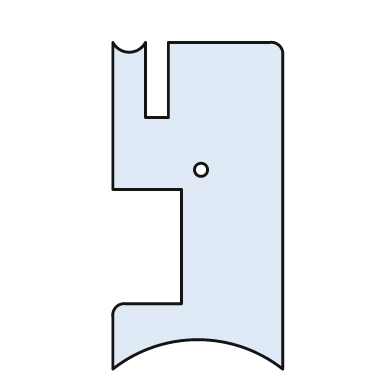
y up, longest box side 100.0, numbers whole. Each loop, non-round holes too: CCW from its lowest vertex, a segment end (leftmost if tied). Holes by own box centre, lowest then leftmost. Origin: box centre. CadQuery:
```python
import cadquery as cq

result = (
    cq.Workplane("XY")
    .moveTo(-26.0, -50.0)
    .threePointArc((0.0, -41.0), (26.0, -50.0))
    .lineTo(26.0, 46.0)
    .threePointArc((25.0, 49.0), (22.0, 50.0))
    .lineTo(-9.0, 50.0)
    .lineTo(-9.0, 27.0)
    .lineTo(-16.0, 27.0)
    .lineTo(-16.0, 50.0)
    .threePointArc((-21.0, 47.0), (-26.0, 50.0))
    .lineTo(-26.0, 5.0)
    .lineTo(-5.0, 5.0)
    .lineTo(-5.0, -30.0)
    .lineTo(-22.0, -30.0)
    .threePointArc((-25.0, -31.0), (-26.0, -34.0))
    .close()
    .moveTo(1.0, 11.0)
    .circle(2.0)
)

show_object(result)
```